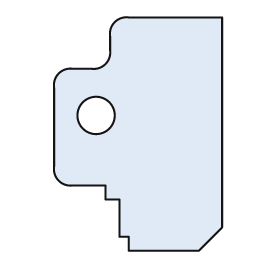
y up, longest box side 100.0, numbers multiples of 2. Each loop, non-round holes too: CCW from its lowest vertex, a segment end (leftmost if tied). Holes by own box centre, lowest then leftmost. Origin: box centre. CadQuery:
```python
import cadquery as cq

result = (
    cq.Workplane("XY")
    .moveTo(-4.0, -50.0)
    .lineTo(26.0, -50.0)
    .lineTo(36.0, -40.0)
    .lineTo(36.0, 50.0)
    .lineTo(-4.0, 50.0)
    .threePointArc((-10.0, 48.0), (-12.0, 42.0))
    .lineTo(-12.0, 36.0)
    .threePointArc((-14.0, 30.0), (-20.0, 28.0))
    .lineTo(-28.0, 28.0)
    .threePointArc((-34.0, 26.0), (-36.0, 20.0))
    .lineTo(-36.0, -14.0)
    .threePointArc((-34.0, -20.0), (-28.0, -22.0))
    .lineTo(-14.0, -22.0)
    .lineTo(-14.0, -28.0)
    .lineTo(-8.0, -28.0)
    .lineTo(-8.0, -44.0)
    .lineTo(-4.0, -44.0)
    .close()
    .moveTo(-18.0, 8.0)
    .circle(8.0)
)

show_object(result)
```